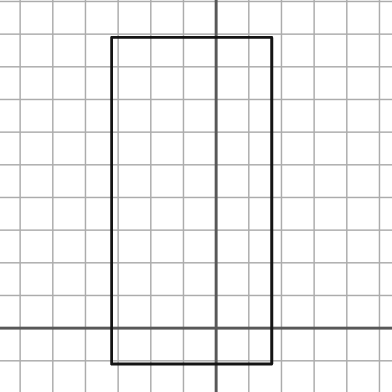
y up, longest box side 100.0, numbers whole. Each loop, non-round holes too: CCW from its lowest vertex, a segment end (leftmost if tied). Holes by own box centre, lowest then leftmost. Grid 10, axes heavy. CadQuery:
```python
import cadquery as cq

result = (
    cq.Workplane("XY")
    .moveTo(-32.0, -11.0)
    .lineTo(17.0, -11.0)
    .lineTo(17.0, 89.0)
    .lineTo(-32.0, 89.0)
    .close()
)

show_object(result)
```